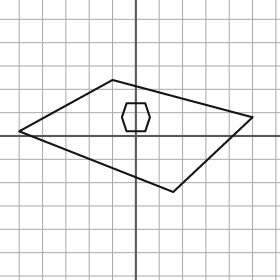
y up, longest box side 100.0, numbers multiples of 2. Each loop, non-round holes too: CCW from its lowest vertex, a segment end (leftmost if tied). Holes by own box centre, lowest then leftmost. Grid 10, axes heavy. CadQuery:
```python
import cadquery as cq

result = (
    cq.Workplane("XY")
    .moveTo(16.0, -24.0)
    .lineTo(50.0, 8.0)
    .lineTo(-10.0, 24.0)
    .lineTo(-50.0, 2.0)
    .close()
    .moveTo(-4.0, 2.0)
    .lineTo(4.0, 2.0)
    .lineTo(6.0, 8.0)
    .lineTo(4.0, 14.0)
    .lineTo(-4.0, 14.0)
    .lineTo(-6.0, 8.0)
    .close()
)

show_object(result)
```